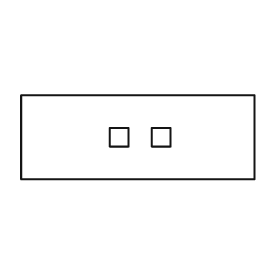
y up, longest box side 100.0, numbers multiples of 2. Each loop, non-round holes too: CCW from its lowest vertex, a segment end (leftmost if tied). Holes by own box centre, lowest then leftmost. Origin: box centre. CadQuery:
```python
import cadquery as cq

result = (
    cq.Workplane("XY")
    .moveTo(-50.0, -18.0)
    .lineTo(50.0, -18.0)
    .lineTo(50.0, 18.0)
    .lineTo(-50.0, 18.0)
    .close()
    .moveTo(-12.0, -4.0)
    .lineTo(-4.0, -4.0)
    .lineTo(-4.0, 4.0)
    .lineTo(-12.0, 4.0)
    .close()
    .moveTo(6.0, -4.0)
    .lineTo(14.0, -4.0)
    .lineTo(14.0, 4.0)
    .lineTo(6.0, 4.0)
    .close()
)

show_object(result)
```